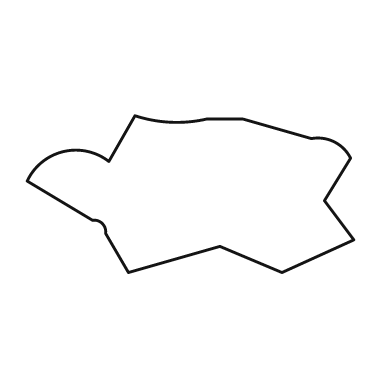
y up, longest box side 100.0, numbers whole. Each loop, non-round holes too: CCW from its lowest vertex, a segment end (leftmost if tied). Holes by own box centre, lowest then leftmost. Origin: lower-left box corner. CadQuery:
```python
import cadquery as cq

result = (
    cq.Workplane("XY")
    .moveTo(31.0, 0.0)
    .lineTo(59.0, 8.0)
    .lineTo(78.0, 0.0)
    .lineTo(100.0, 10.0)
    .lineTo(91.0, 22.0)
    .lineTo(99.0, 35.0)
    .threePointArc((94.0, 40.0), (87.0, 41.0))
    .lineTo(66.0, 47.0)
    .lineTo(55.0, 47.0)
    .threePointArc((44.0, 46.0), (33.0, 48.0))
    .lineTo(25.0, 34.0)
    .threePointArc((11.0, 37.0), (0.0, 28.0))
    .lineTo(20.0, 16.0)
    .threePointArc((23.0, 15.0), (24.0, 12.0))
    .close()
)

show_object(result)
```